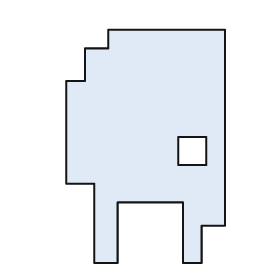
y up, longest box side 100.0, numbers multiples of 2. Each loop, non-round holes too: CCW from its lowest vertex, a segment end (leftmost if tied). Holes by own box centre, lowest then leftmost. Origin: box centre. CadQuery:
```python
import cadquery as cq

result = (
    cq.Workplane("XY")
    .moveTo(-22.0, -50.0)
    .lineTo(-12.0, -50.0)
    .lineTo(-12.0, -24.0)
    .lineTo(16.0, -24.0)
    .lineTo(16.0, -50.0)
    .lineTo(24.0, -50.0)
    .lineTo(24.0, -34.0)
    .lineTo(34.0, -34.0)
    .lineTo(34.0, 50.0)
    .lineTo(-16.0, 50.0)
    .lineTo(-16.0, 42.0)
    .lineTo(-26.0, 42.0)
    .lineTo(-26.0, 28.0)
    .lineTo(-34.0, 28.0)
    .lineTo(-34.0, -16.0)
    .lineTo(-22.0, -16.0)
    .close()
    .moveTo(14.0, -8.0)
    .lineTo(26.0, -8.0)
    .lineTo(26.0, 4.0)
    .lineTo(14.0, 4.0)
    .close()
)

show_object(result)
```